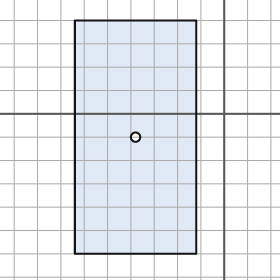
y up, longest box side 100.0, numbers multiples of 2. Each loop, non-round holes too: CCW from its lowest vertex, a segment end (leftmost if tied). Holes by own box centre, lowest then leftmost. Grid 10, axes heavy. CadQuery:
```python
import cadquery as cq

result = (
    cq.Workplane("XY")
    .moveTo(-64.0, -60.0)
    .lineTo(-12.0, -60.0)
    .lineTo(-12.0, 40.0)
    .lineTo(-64.0, 40.0)
    .close()
    .moveTo(-38.0, -10.0)
    .circle(2.0)
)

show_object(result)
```